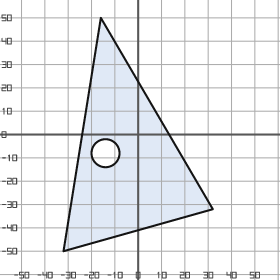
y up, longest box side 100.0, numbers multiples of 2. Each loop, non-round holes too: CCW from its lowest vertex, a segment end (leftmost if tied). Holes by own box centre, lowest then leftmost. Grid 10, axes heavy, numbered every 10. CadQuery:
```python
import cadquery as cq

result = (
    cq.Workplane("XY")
    .moveTo(-32.0, -50.0)
    .lineTo(32.0, -32.0)
    .lineTo(-16.0, 50.0)
    .close()
    .moveTo(-14.0, -8.0)
    .circle(6.0)
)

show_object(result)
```